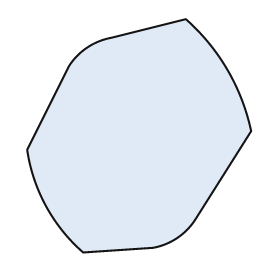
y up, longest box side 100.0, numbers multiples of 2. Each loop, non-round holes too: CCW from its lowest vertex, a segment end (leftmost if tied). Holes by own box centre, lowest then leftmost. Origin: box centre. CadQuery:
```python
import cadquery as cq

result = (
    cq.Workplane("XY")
    .moveTo(-24.0, -50.0)
    .lineTo(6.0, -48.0)
    .threePointArc((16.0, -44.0), (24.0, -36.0))
    .lineTo(48.0, 2.0)
    .threePointArc((38.0, 28.0), (20.0, 50.0))
    .lineTo(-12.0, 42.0)
    .threePointArc((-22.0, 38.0), (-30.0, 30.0))
    .lineTo(-48.0, -6.0)
    .threePointArc((-40.0, -30.0), (-24.0, -50.0))
    .close()
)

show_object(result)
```